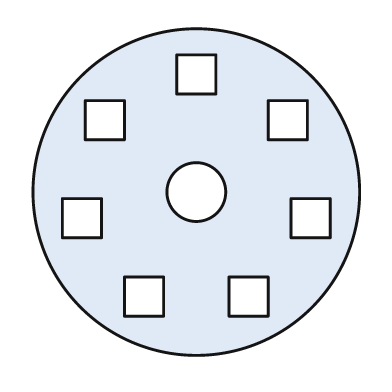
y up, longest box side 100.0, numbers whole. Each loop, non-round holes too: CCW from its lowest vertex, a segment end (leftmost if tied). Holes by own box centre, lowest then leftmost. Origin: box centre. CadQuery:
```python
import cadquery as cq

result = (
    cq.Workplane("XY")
    .moveTo(0.0, 0.0)
    .circle(50.0)
    .moveTo(-22.0, -38.0)
    .lineTo(-10.0, -38.0)
    .lineTo(-10.0, -26.0)
    .lineTo(-22.0, -26.0)
    .close()
    .moveTo(10.0, -38.0)
    .lineTo(22.0, -38.0)
    .lineTo(22.0, -26.0)
    .lineTo(10.0, -26.0)
    .close()
    .moveTo(-41.0, -14.0)
    .lineTo(-29.0, -14.0)
    .lineTo(-29.0, -2.0)
    .lineTo(-41.0, -2.0)
    .close()
    .moveTo(29.0, -14.0)
    .lineTo(41.0, -14.0)
    .lineTo(41.0, -2.0)
    .lineTo(29.0, -2.0)
    .close()
    .moveTo(0.0, 0.0)
    .circle(9.0)
    .moveTo(-34.0, 16.0)
    .lineTo(-22.0, 16.0)
    .lineTo(-22.0, 28.0)
    .lineTo(-34.0, 28.0)
    .close()
    .moveTo(22.0, 16.0)
    .lineTo(34.0, 16.0)
    .lineTo(34.0, 28.0)
    .lineTo(22.0, 28.0)
    .close()
    .moveTo(-6.0, 30.0)
    .lineTo(6.0, 30.0)
    .lineTo(6.0, 42.0)
    .lineTo(-6.0, 42.0)
    .close()
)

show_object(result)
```